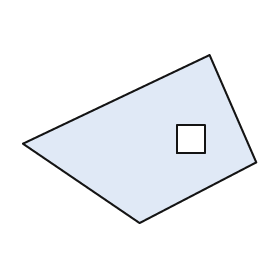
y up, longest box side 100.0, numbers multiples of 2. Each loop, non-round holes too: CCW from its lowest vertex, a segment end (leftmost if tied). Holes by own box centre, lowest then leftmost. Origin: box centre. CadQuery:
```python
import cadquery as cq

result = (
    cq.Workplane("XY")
    .moveTo(0.0, -36.0)
    .lineTo(50.0, -10.0)
    .lineTo(30.0, 36.0)
    .lineTo(-50.0, -2.0)
    .close()
    .moveTo(16.0, -6.0)
    .lineTo(28.0, -6.0)
    .lineTo(28.0, 6.0)
    .lineTo(16.0, 6.0)
    .close()
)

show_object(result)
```